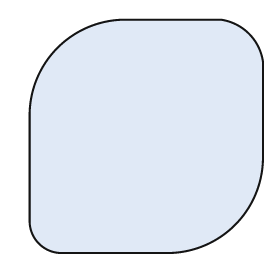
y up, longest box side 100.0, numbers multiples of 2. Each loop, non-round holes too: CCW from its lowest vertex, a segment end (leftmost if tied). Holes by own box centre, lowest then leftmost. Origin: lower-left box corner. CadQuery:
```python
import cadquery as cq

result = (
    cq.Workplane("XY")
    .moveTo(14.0, 0.0)
    .lineTo(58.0, 0.0)
    .threePointArc((88.0, 12.0), (100.0, 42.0))
    .lineTo(100.0, 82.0)
    .threePointArc((94.0, 94.0), (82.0, 100.0))
    .lineTo(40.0, 100.0)
    .threePointArc((12.0, 88.0), (0.0, 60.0))
    .lineTo(0.0, 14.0)
    .threePointArc((4.0, 4.0), (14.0, 0.0))
    .close()
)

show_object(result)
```